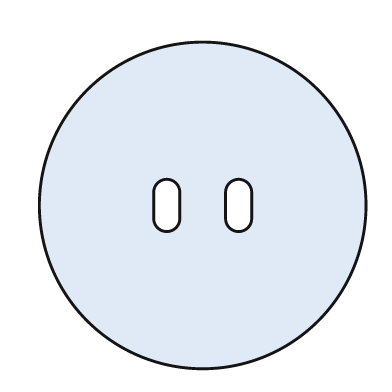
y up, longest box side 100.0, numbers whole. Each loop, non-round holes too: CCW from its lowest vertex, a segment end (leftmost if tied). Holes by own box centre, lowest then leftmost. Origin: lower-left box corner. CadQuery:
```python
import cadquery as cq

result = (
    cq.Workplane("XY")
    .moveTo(50.0, 50.0)
    .circle(50.0)
    .moveTo(35.0, 46.0)
    .threePointArc((39.0, 42.0), (43.0, 46.0))
    .lineTo(43.0, 54.0)
    .threePointArc((39.0, 58.0), (35.0, 54.0))
    .close()
    .moveTo(57.0, 46.0)
    .threePointArc((61.0, 42.0), (65.0, 46.0))
    .lineTo(65.0, 54.0)
    .threePointArc((61.0, 58.0), (57.0, 54.0))
    .close()
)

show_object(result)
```